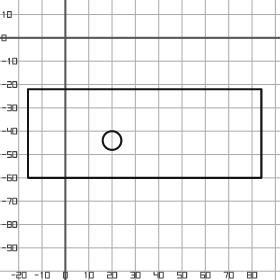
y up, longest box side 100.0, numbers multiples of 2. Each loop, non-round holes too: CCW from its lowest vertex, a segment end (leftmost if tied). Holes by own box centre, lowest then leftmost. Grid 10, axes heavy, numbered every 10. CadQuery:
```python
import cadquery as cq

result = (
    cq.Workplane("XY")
    .moveTo(-16.0, -60.0)
    .lineTo(84.0, -60.0)
    .lineTo(84.0, -22.0)
    .lineTo(-16.0, -22.0)
    .close()
    .moveTo(20.0, -44.0)
    .circle(4.0)
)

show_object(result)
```